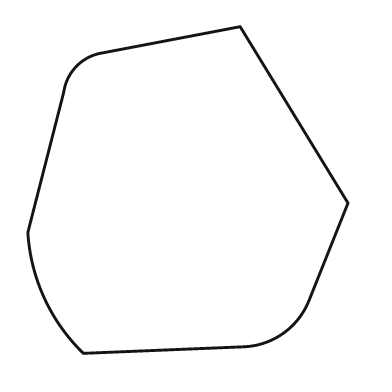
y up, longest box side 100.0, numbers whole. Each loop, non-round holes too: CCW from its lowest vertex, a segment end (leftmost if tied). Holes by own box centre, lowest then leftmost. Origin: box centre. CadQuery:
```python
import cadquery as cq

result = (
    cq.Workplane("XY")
    .moveTo(-32.0, -50.0)
    .lineTo(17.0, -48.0)
    .threePointArc((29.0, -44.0), (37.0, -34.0))
    .lineTo(49.0, -4.0)
    .lineTo(16.0, 50.0)
    .lineTo(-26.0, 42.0)
    .threePointArc((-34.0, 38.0), (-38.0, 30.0))
    .lineTo(-49.0, -13.0)
    .threePointArc((-44.0, -33.0), (-32.0, -50.0))
    .close()
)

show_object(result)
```